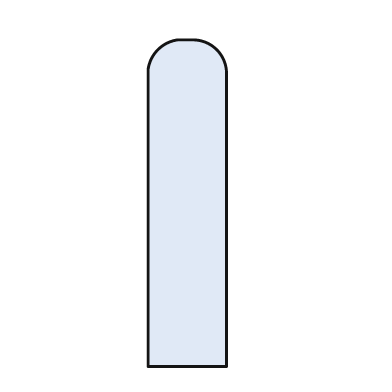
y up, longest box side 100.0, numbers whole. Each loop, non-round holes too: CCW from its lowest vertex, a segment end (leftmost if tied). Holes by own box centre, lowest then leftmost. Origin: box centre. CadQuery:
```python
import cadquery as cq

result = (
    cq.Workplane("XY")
    .moveTo(-12.0, -50.0)
    .lineTo(12.0, -50.0)
    .lineTo(12.0, 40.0)
    .threePointArc((9.0, 47.0), (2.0, 50.0))
    .lineTo(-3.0, 50.0)
    .threePointArc((-9.0, 47.0), (-12.0, 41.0))
    .close()
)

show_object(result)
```